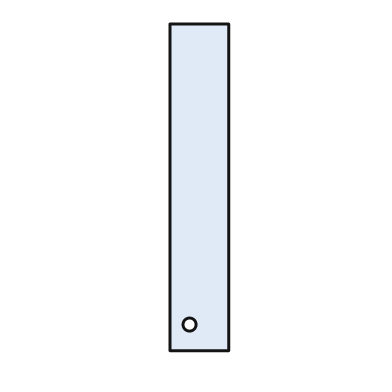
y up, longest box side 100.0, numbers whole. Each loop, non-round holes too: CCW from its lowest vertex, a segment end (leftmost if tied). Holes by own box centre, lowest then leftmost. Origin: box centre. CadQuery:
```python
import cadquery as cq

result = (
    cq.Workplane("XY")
    .moveTo(-9.0, -50.0)
    .lineTo(9.0, -50.0)
    .lineTo(9.0, 50.0)
    .lineTo(-9.0, 50.0)
    .close()
    .moveTo(-3.0, -42.0)
    .circle(2.0)
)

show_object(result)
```